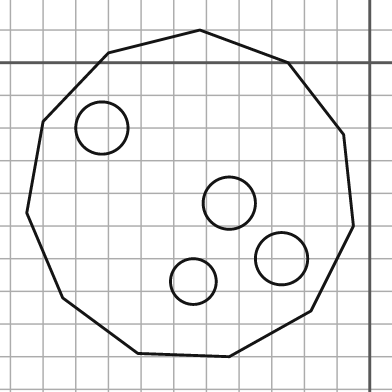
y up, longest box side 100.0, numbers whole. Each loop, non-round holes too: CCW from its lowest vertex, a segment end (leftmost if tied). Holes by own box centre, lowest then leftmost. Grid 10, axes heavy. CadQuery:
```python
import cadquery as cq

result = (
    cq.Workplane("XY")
    .moveTo(-43.0, -90.0)
    .lineTo(-18.0, -76.0)
    .lineTo(-5.0, -50.0)
    .lineTo(-8.0, -22.0)
    .lineTo(-25.0, 0.0)
    .lineTo(-52.0, 10.0)
    .lineTo(-80.0, 3.0)
    .lineTo(-100.0, -18.0)
    .lineTo(-105.0, -46.0)
    .lineTo(-94.0, -72.0)
    .lineTo(-71.0, -89.0)
    .close()
    .moveTo(-54.0, -67.0)
    .circle(7.0)
    .moveTo(-27.0, -60.0)
    .circle(8.0)
    .moveTo(-43.0, -43.0)
    .circle(8.0)
    .moveTo(-82.0, -20.0)
    .circle(8.0)
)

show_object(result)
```